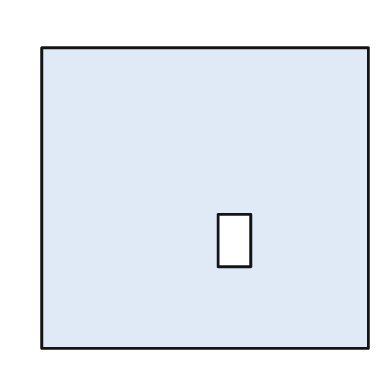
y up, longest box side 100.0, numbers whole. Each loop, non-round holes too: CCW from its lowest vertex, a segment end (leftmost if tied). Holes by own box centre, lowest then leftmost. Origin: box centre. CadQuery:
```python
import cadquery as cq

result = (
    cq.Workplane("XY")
    .moveTo(-50.0, -46.0)
    .lineTo(50.0, -46.0)
    .lineTo(50.0, 46.0)
    .lineTo(-50.0, 46.0)
    .close()
    .moveTo(4.0, -21.0)
    .lineTo(14.0, -21.0)
    .lineTo(14.0, -5.0)
    .lineTo(4.0, -5.0)
    .close()
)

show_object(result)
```